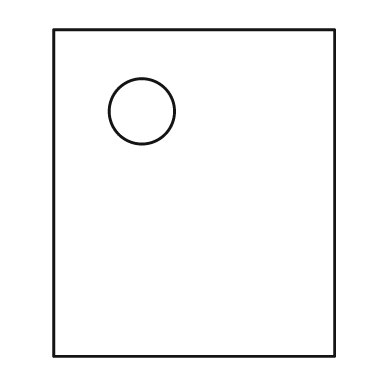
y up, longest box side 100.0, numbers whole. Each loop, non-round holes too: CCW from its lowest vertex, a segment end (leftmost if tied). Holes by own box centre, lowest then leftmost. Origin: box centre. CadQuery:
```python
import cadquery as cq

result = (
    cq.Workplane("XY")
    .moveTo(-43.0, -50.0)
    .lineTo(43.0, -50.0)
    .lineTo(43.0, 50.0)
    .lineTo(-43.0, 50.0)
    .close()
    .moveTo(-16.0, 25.0)
    .circle(10.0)
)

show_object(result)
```